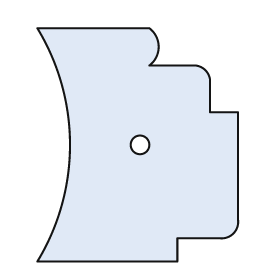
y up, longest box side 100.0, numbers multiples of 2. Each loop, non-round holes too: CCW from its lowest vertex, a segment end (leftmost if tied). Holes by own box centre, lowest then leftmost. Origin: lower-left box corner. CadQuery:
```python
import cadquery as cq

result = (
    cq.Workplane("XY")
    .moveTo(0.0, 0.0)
    .lineTo(60.0, 0.0)
    .lineTo(60.0, 10.0)
    .lineTo(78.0, 10.0)
    .threePointArc((84.0, 12.0), (86.0, 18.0))
    .lineTo(86.0, 64.0)
    .lineTo(74.0, 64.0)
    .lineTo(74.0, 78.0)
    .threePointArc((72.0, 82.0), (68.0, 84.0))
    .lineTo(48.0, 84.0)
    .threePointArc((52.0, 92.0), (48.0, 100.0))
    .lineTo(0.0, 100.0)
    .threePointArc((14.0, 50.0), (0.0, 0.0))
    .close()
    .moveTo(44.0, 50.0)
    .circle(4.0)
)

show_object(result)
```